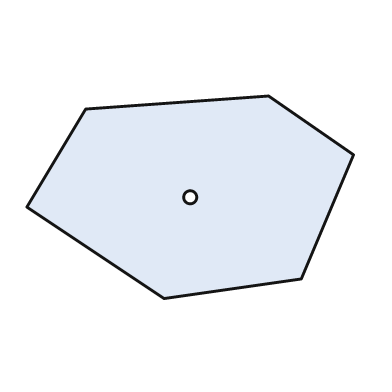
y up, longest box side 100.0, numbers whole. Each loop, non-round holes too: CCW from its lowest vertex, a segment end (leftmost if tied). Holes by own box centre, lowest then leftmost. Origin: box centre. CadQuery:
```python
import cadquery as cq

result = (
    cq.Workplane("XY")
    .moveTo(-8.0, -31.0)
    .lineTo(34.0, -25.0)
    .lineTo(50.0, 13.0)
    .lineTo(24.0, 31.0)
    .lineTo(-32.0, 27.0)
    .lineTo(-50.0, -3.0)
    .close()
    .moveTo(0.0, 0.0)
    .circle(2.0)
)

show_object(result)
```